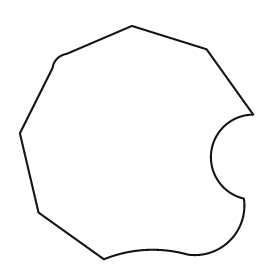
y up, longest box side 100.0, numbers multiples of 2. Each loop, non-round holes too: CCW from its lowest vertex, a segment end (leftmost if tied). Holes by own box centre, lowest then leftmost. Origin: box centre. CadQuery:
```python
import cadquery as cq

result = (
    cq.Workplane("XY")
    .moveTo(-14.0, -50.0)
    .threePointArc((4.0, -46.0), (22.0, -48.0))
    .threePointArc((40.0, -42.0), (46.0, -24.0))
    .threePointArc((32.0, -4.0), (50.0, 12.0))
    .lineTo(30.0, 40.0)
    .lineTo(-2.0, 50.0)
    .lineTo(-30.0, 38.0)
    .threePointArc((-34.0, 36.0), (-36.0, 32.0))
    .lineTo(-50.0, 4.0)
    .lineTo(-42.0, -30.0)
    .close()
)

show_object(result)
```